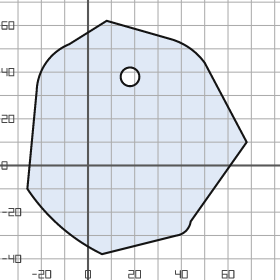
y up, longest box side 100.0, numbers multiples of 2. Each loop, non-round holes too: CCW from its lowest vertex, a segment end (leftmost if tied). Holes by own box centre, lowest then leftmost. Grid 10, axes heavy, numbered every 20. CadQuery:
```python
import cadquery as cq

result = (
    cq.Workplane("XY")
    .moveTo(6.0, -38.0)
    .lineTo(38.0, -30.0)
    .threePointArc((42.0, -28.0), (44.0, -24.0))
    .lineTo(68.0, 10.0)
    .lineTo(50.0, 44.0)
    .threePointArc((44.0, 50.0), (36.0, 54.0))
    .lineTo(8.0, 62.0)
    .lineTo(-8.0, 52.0)
    .threePointArc((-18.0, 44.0), (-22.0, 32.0))
    .lineTo(-26.0, -10.0)
    .threePointArc((-12.0, -26.0), (6.0, -38.0))
    .close()
    .moveTo(18.0, 38.0)
    .circle(4.0)
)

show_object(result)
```